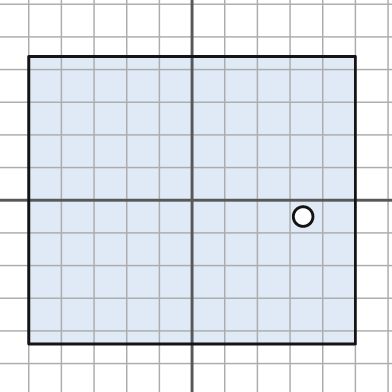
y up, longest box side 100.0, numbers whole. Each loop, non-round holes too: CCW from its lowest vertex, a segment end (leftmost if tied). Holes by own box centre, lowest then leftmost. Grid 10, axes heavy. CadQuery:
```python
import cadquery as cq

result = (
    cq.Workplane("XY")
    .moveTo(-50.0, -44.0)
    .lineTo(50.0, -44.0)
    .lineTo(50.0, 44.0)
    .lineTo(-50.0, 44.0)
    .close()
    .moveTo(34.0, -5.0)
    .circle(3.0)
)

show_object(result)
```